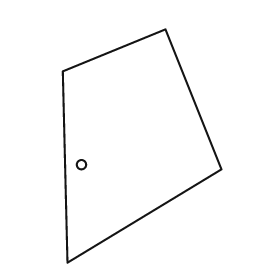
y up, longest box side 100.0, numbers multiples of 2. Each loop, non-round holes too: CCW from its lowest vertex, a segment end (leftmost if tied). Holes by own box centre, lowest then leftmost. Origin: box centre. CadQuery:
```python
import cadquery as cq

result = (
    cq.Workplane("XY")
    .moveTo(-32.0, -50.0)
    .lineTo(34.0, -10.0)
    .lineTo(10.0, 50.0)
    .lineTo(-34.0, 32.0)
    .close()
    .moveTo(-26.0, -8.0)
    .circle(2.0)
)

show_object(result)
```